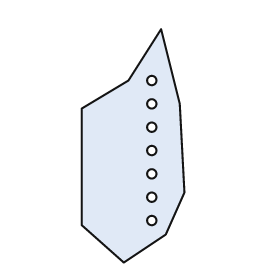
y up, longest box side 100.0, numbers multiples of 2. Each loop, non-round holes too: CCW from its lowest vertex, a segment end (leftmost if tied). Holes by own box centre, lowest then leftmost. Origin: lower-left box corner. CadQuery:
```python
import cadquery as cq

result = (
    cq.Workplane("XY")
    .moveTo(18.0, 0.0)
    .lineTo(36.0, 12.0)
    .lineTo(44.0, 30.0)
    .lineTo(42.0, 68.0)
    .lineTo(34.0, 100.0)
    .lineTo(20.0, 78.0)
    .lineTo(0.0, 66.0)
    .lineTo(0.0, 16.0)
    .close()
    .moveTo(30.0, 18.0)
    .circle(2.0)
    .moveTo(30.0, 28.0)
    .circle(2.0)
    .moveTo(30.0, 38.0)
    .circle(2.0)
    .moveTo(30.0, 48.0)
    .circle(2.0)
    .moveTo(30.0, 58.0)
    .circle(2.0)
    .moveTo(30.0, 68.0)
    .circle(2.0)
    .moveTo(30.0, 78.0)
    .circle(2.0)
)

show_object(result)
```